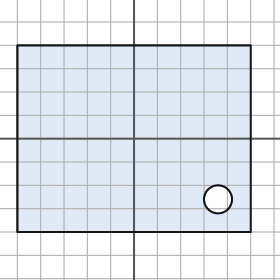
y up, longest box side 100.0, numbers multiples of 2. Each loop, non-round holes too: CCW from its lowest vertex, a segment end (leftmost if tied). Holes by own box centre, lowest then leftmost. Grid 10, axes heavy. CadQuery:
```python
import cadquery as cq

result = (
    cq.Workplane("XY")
    .moveTo(-50.0, -40.0)
    .lineTo(50.0, -40.0)
    .lineTo(50.0, 40.0)
    .lineTo(-50.0, 40.0)
    .close()
    .moveTo(36.0, -26.0)
    .circle(6.0)
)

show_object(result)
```